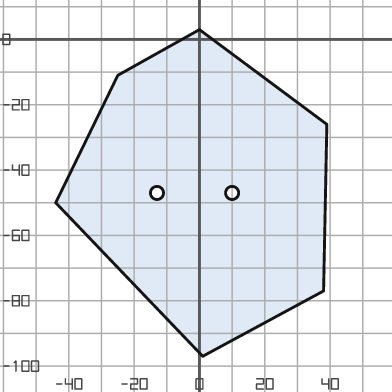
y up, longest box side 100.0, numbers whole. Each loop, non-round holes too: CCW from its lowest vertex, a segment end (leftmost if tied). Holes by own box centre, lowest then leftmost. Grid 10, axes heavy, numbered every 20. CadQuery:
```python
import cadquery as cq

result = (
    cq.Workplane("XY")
    .moveTo(1.0, -97.0)
    .lineTo(38.0, -77.0)
    .lineTo(39.0, -26.0)
    .lineTo(0.0, 3.0)
    .lineTo(-25.0, -11.0)
    .lineTo(-44.0, -50.0)
    .close()
    .moveTo(-13.0, -47.0)
    .circle(2.0)
    .moveTo(10.0, -47.0)
    .circle(2.0)
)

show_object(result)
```